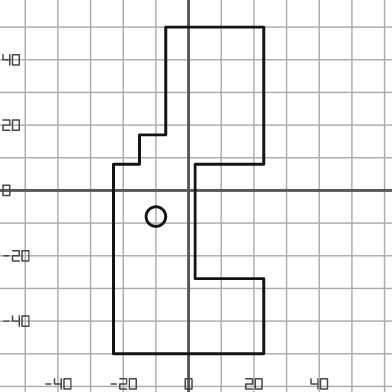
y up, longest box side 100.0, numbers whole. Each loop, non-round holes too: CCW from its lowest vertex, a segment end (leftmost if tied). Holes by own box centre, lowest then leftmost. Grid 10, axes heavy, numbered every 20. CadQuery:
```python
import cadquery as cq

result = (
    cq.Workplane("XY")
    .moveTo(-23.0, -50.0)
    .lineTo(23.0, -50.0)
    .lineTo(23.0, -27.0)
    .lineTo(2.0, -27.0)
    .lineTo(2.0, 8.0)
    .lineTo(23.0, 8.0)
    .lineTo(23.0, 50.0)
    .lineTo(-7.0, 50.0)
    .lineTo(-7.0, 17.0)
    .lineTo(-15.0, 17.0)
    .lineTo(-15.0, 8.0)
    .lineTo(-23.0, 8.0)
    .close()
    .moveTo(-10.0, -8.0)
    .circle(3.0)
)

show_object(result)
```